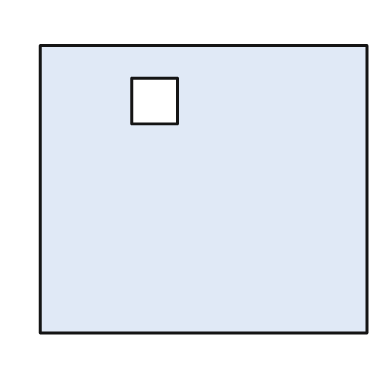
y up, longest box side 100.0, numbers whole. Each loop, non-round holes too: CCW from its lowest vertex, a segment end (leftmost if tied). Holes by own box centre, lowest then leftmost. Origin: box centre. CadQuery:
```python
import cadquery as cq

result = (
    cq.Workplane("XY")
    .moveTo(-50.0, -44.0)
    .lineTo(50.0, -44.0)
    .lineTo(50.0, 44.0)
    .lineTo(-50.0, 44.0)
    .close()
    .moveTo(-22.0, 20.0)
    .lineTo(-8.0, 20.0)
    .lineTo(-8.0, 34.0)
    .lineTo(-22.0, 34.0)
    .close()
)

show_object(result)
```